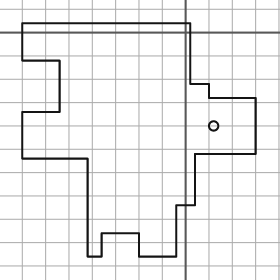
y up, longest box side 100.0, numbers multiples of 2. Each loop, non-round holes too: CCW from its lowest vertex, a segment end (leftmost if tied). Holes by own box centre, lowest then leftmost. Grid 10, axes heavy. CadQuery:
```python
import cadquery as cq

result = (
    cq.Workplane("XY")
    .moveTo(-42.0, -96.0)
    .lineTo(-36.0, -96.0)
    .lineTo(-36.0, -86.0)
    .lineTo(-20.0, -86.0)
    .lineTo(-20.0, -96.0)
    .lineTo(-4.0, -96.0)
    .lineTo(-4.0, -74.0)
    .lineTo(4.0, -74.0)
    .lineTo(4.0, -52.0)
    .lineTo(30.0, -52.0)
    .lineTo(30.0, -28.0)
    .lineTo(10.0, -28.0)
    .lineTo(10.0, -22.0)
    .lineTo(2.0, -22.0)
    .lineTo(2.0, 4.0)
    .lineTo(-70.0, 4.0)
    .lineTo(-70.0, -12.0)
    .lineTo(-54.0, -12.0)
    .lineTo(-54.0, -34.0)
    .lineTo(-70.0, -34.0)
    .lineTo(-70.0, -54.0)
    .lineTo(-42.0, -54.0)
    .close()
    .moveTo(12.0, -40.0)
    .circle(2.0)
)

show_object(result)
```